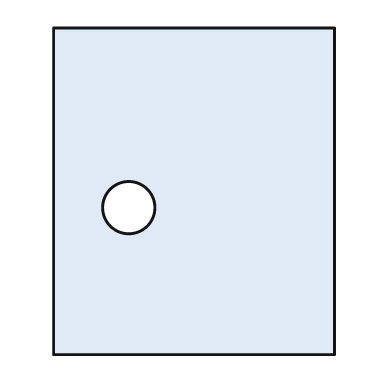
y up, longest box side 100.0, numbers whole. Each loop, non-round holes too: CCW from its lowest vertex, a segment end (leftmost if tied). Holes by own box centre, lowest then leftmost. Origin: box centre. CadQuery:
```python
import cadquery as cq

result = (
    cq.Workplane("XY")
    .moveTo(-43.0, -50.0)
    .lineTo(43.0, -50.0)
    .lineTo(43.0, 50.0)
    .lineTo(-43.0, 50.0)
    .close()
    .moveTo(-20.0, -5.0)
    .circle(8.0)
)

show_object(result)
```